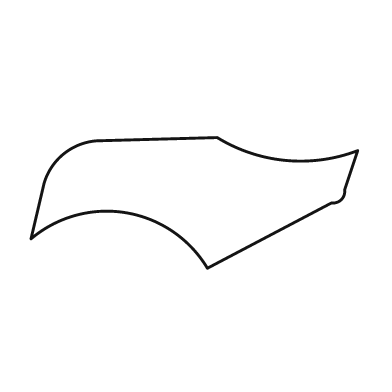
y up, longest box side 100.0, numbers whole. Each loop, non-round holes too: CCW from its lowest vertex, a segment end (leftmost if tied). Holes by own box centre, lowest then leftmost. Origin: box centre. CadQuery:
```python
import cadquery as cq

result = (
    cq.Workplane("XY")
    .moveTo(4.0, -20.0)
    .lineTo(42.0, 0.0)
    .threePointArc((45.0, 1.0), (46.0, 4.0))
    .lineTo(50.0, 16.0)
    .threePointArc((28.0, 13.0), (7.0, 20.0))
    .lineTo(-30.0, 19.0)
    .threePointArc((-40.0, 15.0), (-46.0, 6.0))
    .lineTo(-50.0, -11.0)
    .threePointArc((-21.0, -3.0), (4.0, -20.0))
    .close()
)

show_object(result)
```